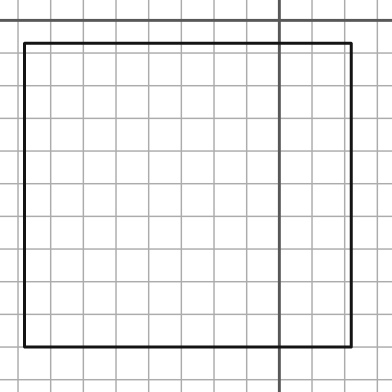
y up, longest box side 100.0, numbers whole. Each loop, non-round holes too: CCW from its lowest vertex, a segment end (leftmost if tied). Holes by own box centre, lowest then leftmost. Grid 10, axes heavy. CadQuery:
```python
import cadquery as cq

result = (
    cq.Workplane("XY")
    .moveTo(-78.0, -100.0)
    .lineTo(22.0, -100.0)
    .lineTo(22.0, -7.0)
    .lineTo(-78.0, -7.0)
    .close()
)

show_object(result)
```